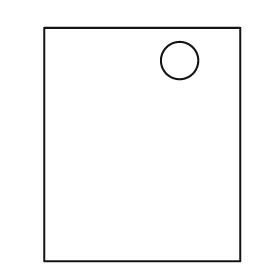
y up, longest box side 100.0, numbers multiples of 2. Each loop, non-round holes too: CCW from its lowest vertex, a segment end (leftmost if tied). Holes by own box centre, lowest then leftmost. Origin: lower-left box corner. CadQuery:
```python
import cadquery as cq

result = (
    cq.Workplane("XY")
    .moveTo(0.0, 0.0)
    .lineTo(84.0, 0.0)
    .lineTo(84.0, 100.0)
    .lineTo(0.0, 100.0)
    .close()
    .moveTo(58.0, 86.0)
    .circle(8.0)
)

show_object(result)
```